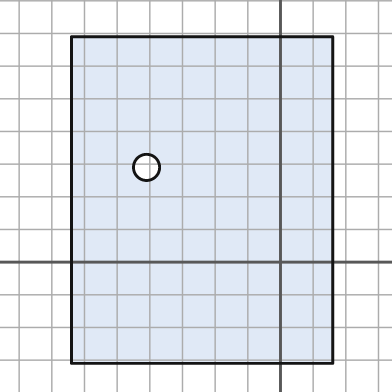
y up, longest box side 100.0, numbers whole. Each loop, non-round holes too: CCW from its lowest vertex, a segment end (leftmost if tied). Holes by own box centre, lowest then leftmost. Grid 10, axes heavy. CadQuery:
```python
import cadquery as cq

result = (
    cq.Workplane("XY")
    .moveTo(-64.0, -31.0)
    .lineTo(16.0, -31.0)
    .lineTo(16.0, 69.0)
    .lineTo(-64.0, 69.0)
    .close()
    .moveTo(-41.0, 29.0)
    .circle(4.0)
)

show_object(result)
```